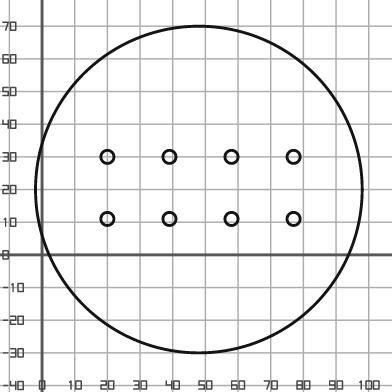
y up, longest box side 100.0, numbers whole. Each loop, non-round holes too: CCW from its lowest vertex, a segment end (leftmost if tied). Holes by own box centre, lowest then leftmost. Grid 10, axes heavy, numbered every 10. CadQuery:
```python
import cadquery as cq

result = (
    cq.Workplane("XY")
    .moveTo(48.0, 20.0)
    .circle(50.0)
    .moveTo(20.0, 11.0)
    .circle(2.0)
    .moveTo(39.0, 11.0)
    .circle(2.0)
    .moveTo(58.0, 11.0)
    .circle(2.0)
    .moveTo(77.0, 11.0)
    .circle(2.0)
    .moveTo(20.0, 30.0)
    .circle(2.0)
    .moveTo(39.0, 30.0)
    .circle(2.0)
    .moveTo(58.0, 30.0)
    .circle(2.0)
    .moveTo(77.0, 30.0)
    .circle(2.0)
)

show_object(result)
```